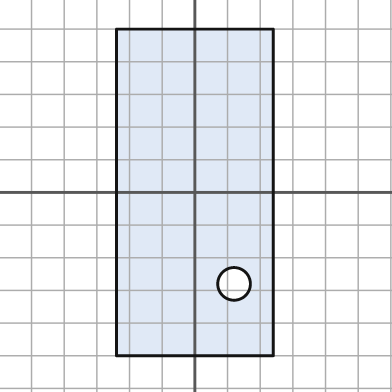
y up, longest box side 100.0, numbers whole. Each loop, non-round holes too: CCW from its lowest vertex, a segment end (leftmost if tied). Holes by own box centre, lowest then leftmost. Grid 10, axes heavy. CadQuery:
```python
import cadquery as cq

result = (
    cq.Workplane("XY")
    .moveTo(-24.0, -50.0)
    .lineTo(24.0, -50.0)
    .lineTo(24.0, 50.0)
    .lineTo(-24.0, 50.0)
    .close()
    .moveTo(12.0, -28.0)
    .circle(5.0)
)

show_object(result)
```